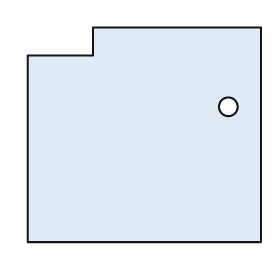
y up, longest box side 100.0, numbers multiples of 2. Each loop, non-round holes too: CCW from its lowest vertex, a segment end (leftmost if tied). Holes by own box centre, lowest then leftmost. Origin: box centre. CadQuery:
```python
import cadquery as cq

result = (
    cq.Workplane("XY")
    .moveTo(-50.0, -46.0)
    .lineTo(50.0, -46.0)
    .lineTo(50.0, 46.0)
    .lineTo(-22.0, 46.0)
    .lineTo(-22.0, 34.0)
    .lineTo(-50.0, 34.0)
    .close()
    .moveTo(36.0, 12.0)
    .circle(4.0)
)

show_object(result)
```